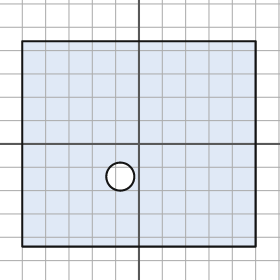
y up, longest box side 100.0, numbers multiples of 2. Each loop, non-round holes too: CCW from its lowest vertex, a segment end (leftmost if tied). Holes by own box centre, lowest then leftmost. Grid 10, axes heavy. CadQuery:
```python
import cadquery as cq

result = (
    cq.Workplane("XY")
    .moveTo(-50.0, -44.0)
    .lineTo(50.0, -44.0)
    .lineTo(50.0, 44.0)
    .lineTo(-50.0, 44.0)
    .close()
    .moveTo(-8.0, -14.0)
    .circle(6.0)
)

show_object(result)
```